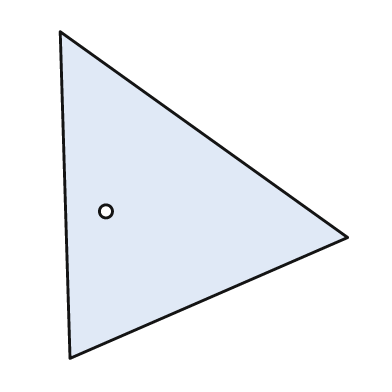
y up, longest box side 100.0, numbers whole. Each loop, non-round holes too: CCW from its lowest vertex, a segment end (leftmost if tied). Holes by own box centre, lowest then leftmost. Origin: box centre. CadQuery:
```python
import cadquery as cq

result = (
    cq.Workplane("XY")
    .moveTo(-41.0, -50.0)
    .lineTo(44.0, -13.0)
    .lineTo(-44.0, 50.0)
    .close()
    .moveTo(-30.0, -5.0)
    .circle(2.0)
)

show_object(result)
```